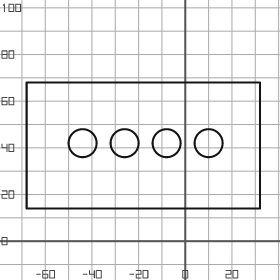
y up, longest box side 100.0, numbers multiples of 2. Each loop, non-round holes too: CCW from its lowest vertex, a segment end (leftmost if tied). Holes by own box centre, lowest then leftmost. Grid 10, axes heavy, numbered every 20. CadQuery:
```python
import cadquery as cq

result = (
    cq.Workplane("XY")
    .moveTo(-68.0, 14.0)
    .lineTo(32.0, 14.0)
    .lineTo(32.0, 68.0)
    .lineTo(-68.0, 68.0)
    .close()
    .moveTo(-44.0, 42.0)
    .circle(6.0)
    .moveTo(-26.0, 42.0)
    .circle(6.0)
    .moveTo(-8.0, 42.0)
    .circle(6.0)
    .moveTo(10.0, 42.0)
    .circle(6.0)
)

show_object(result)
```